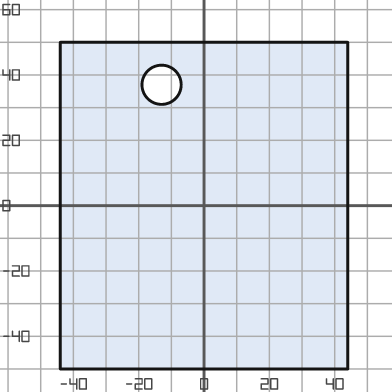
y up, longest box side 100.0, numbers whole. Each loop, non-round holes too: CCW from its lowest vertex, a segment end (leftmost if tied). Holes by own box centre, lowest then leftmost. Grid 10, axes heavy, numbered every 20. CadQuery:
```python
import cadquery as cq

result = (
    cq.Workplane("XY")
    .moveTo(-44.0, -50.0)
    .lineTo(44.0, -50.0)
    .lineTo(44.0, 50.0)
    .lineTo(-44.0, 50.0)
    .close()
    .moveTo(-13.0, 37.0)
    .circle(6.0)
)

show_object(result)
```